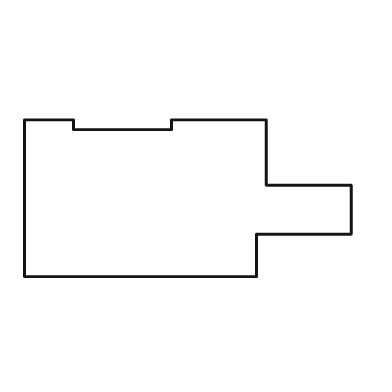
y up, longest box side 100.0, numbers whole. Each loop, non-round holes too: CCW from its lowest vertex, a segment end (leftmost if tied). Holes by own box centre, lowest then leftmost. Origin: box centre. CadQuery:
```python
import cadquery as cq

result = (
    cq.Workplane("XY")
    .moveTo(-50.0, -24.0)
    .lineTo(21.0, -24.0)
    .lineTo(21.0, -11.0)
    .lineTo(50.0, -11.0)
    .lineTo(50.0, 4.0)
    .lineTo(24.0, 4.0)
    .lineTo(24.0, 24.0)
    .lineTo(-5.0, 24.0)
    .lineTo(-5.0, 21.0)
    .lineTo(-35.0, 21.0)
    .lineTo(-35.0, 24.0)
    .lineTo(-50.0, 24.0)
    .close()
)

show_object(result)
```